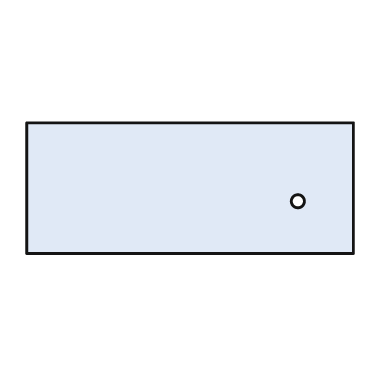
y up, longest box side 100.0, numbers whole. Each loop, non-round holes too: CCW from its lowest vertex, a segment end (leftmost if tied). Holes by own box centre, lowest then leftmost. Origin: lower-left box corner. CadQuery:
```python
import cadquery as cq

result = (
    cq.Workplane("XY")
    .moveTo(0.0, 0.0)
    .lineTo(100.0, 0.0)
    .lineTo(100.0, 40.0)
    .lineTo(0.0, 40.0)
    .close()
    .moveTo(83.0, 16.0)
    .circle(2.0)
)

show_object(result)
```